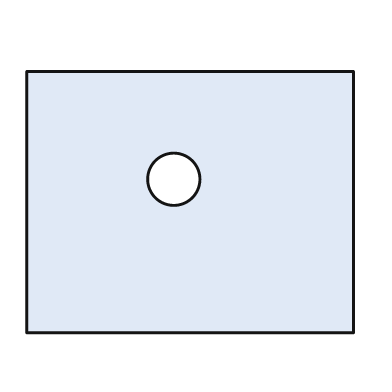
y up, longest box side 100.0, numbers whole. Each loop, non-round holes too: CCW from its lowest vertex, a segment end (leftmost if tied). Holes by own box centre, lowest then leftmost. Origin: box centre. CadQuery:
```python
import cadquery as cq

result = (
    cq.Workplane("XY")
    .moveTo(-50.0, -40.0)
    .lineTo(50.0, -40.0)
    .lineTo(50.0, 40.0)
    .lineTo(-50.0, 40.0)
    .close()
    .moveTo(-5.0, 7.0)
    .circle(8.0)
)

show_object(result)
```